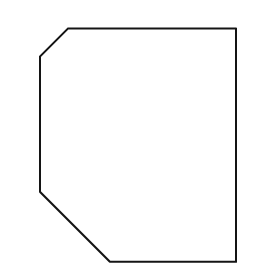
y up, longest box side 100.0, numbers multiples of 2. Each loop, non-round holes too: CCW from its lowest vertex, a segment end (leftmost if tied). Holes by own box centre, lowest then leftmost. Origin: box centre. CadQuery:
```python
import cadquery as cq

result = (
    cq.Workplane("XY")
    .moveTo(-12.0, -50.0)
    .lineTo(42.0, -50.0)
    .lineTo(42.0, 50.0)
    .lineTo(-30.0, 50.0)
    .lineTo(-42.0, 38.0)
    .lineTo(-42.0, -20.0)
    .close()
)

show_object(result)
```